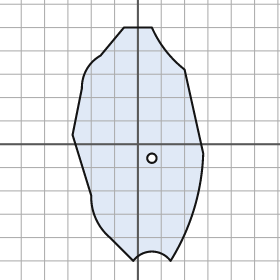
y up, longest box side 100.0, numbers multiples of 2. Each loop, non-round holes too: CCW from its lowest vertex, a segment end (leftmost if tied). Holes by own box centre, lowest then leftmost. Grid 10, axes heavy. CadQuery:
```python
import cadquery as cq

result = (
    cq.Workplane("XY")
    .moveTo(-2.0, -50.0)
    .threePointArc((6.0, -46.0), (14.0, -50.0))
    .threePointArc((24.0, -28.0), (28.0, -4.0))
    .lineTo(20.0, 32.0)
    .threePointArc((12.0, 40.0), (6.0, 50.0))
    .lineTo(-6.0, 50.0)
    .lineTo(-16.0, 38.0)
    .threePointArc((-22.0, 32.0), (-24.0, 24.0))
    .lineTo(-28.0, 4.0)
    .lineTo(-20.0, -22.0)
    .threePointArc((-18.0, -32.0), (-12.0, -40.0))
    .close()
    .moveTo(6.0, -6.0)
    .circle(2.0)
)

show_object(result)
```